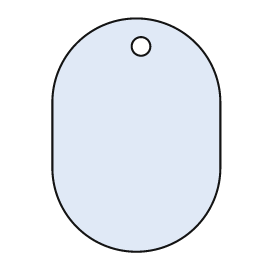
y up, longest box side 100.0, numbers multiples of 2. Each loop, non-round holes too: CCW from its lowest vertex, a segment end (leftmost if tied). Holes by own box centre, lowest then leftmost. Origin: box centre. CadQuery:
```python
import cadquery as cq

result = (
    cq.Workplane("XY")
    .moveTo(-36.0, -14.0)
    .threePointArc((0.0, -50.0), (36.0, -14.0))
    .lineTo(36.0, 14.0)
    .threePointArc((0.0, 50.0), (-36.0, 14.0))
    .close()
    .moveTo(2.0, 38.0)
    .circle(4.0)
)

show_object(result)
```